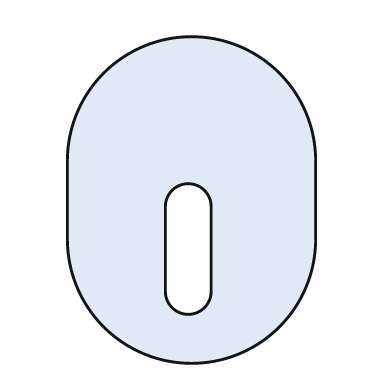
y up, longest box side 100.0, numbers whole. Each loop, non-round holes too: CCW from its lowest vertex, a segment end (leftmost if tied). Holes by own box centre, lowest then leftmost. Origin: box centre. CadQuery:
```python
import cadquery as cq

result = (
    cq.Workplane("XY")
    .moveTo(-38.0, -12.0)
    .threePointArc((0.0, -50.0), (38.0, -12.0))
    .lineTo(38.0, 12.0)
    .threePointArc((0.0, 50.0), (-38.0, 12.0))
    .close()
    .moveTo(-8.0, -28.0)
    .threePointArc((-1.0, -35.0), (6.0, -28.0))
    .lineTo(6.0, -2.0)
    .threePointArc((-1.0, 5.0), (-8.0, -2.0))
    .close()
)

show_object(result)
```